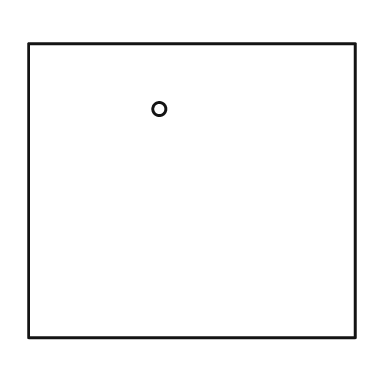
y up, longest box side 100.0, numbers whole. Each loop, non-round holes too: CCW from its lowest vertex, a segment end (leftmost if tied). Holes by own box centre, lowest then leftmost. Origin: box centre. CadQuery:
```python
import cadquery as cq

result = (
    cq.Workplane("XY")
    .moveTo(-50.0, -45.0)
    .lineTo(50.0, -45.0)
    .lineTo(50.0, 45.0)
    .lineTo(-50.0, 45.0)
    .close()
    .moveTo(-10.0, 25.0)
    .circle(2.0)
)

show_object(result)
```